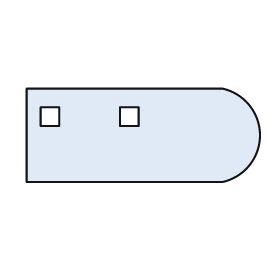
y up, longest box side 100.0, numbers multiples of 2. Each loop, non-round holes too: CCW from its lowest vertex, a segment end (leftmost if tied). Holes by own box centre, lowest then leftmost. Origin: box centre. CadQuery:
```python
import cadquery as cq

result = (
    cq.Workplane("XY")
    .moveTo(-50.0, -20.0)
    .lineTo(34.0, -20.0)
    .threePointArc((50.0, 0.0), (34.0, 20.0))
    .lineTo(-50.0, 20.0)
    .close()
    .moveTo(-44.0, 4.0)
    .lineTo(-36.0, 4.0)
    .lineTo(-36.0, 12.0)
    .lineTo(-44.0, 12.0)
    .close()
    .moveTo(-10.0, 4.0)
    .lineTo(-2.0, 4.0)
    .lineTo(-2.0, 12.0)
    .lineTo(-10.0, 12.0)
    .close()
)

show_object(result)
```